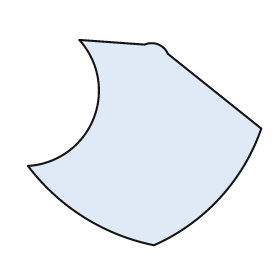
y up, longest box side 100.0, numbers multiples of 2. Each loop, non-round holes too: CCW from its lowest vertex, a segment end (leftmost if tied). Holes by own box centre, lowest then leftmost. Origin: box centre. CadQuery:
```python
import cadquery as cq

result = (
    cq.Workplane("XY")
    .moveTo(4.0, -44.0)
    .threePointArc((32.0, -24.0), (50.0, 6.0))
    .lineTo(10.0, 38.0)
    .threePointArc((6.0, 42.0), (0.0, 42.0))
    .lineTo(-28.0, 44.0)
    .threePointArc((-22.0, 10.0), (-50.0, -10.0))
    .threePointArc((-26.0, -32.0), (4.0, -44.0))
    .close()
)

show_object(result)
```